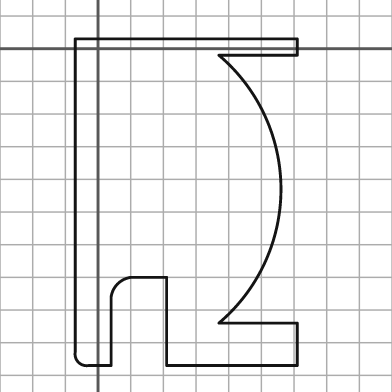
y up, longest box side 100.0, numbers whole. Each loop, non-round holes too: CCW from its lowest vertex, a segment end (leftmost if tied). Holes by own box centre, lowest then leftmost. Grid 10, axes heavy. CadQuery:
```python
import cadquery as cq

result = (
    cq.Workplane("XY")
    .moveTo(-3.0, -97.0)
    .lineTo(4.0, -97.0)
    .lineTo(4.0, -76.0)
    .threePointArc((6.0, -72.0), (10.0, -70.0))
    .lineTo(21.0, -70.0)
    .lineTo(21.0, -97.0)
    .lineTo(61.0, -97.0)
    .lineTo(61.0, -84.0)
    .lineTo(37.0, -84.0)
    .threePointArc((56.0, -43.0), (37.0, -2.0))
    .lineTo(61.0, -2.0)
    .lineTo(61.0, 3.0)
    .lineTo(-7.0, 3.0)
    .lineTo(-7.0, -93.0)
    .threePointArc((-6.0, -96.0), (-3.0, -97.0))
    .close()
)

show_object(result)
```